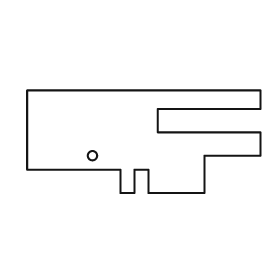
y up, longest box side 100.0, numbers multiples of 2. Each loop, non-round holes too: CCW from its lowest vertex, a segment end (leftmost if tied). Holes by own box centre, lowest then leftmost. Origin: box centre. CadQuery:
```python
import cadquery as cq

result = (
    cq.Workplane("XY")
    .moveTo(-10.0, -22.0)
    .lineTo(-4.0, -22.0)
    .lineTo(-4.0, -12.0)
    .lineTo(2.0, -12.0)
    .lineTo(2.0, -22.0)
    .lineTo(26.0, -22.0)
    .lineTo(26.0, -6.0)
    .lineTo(50.0, -6.0)
    .lineTo(50.0, 4.0)
    .lineTo(6.0, 4.0)
    .lineTo(6.0, 14.0)
    .lineTo(50.0, 14.0)
    .lineTo(50.0, 22.0)
    .lineTo(-50.0, 22.0)
    .lineTo(-50.0, -12.0)
    .lineTo(-10.0, -12.0)
    .close()
    .moveTo(-22.0, -6.0)
    .circle(2.0)
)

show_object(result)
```